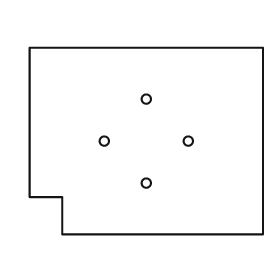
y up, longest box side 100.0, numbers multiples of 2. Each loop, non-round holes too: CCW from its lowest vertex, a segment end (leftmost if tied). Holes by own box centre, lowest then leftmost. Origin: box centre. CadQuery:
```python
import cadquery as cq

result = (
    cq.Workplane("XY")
    .moveTo(-36.0, -40.0)
    .lineTo(50.0, -40.0)
    .lineTo(50.0, 40.0)
    .lineTo(-50.0, 40.0)
    .lineTo(-50.0, -24.0)
    .lineTo(-36.0, -24.0)
    .close()
    .moveTo(0.0, -18.0)
    .circle(2.0)
    .moveTo(-18.0, 0.0)
    .circle(2.0)
    .moveTo(18.0, 0.0)
    .circle(2.0)
    .moveTo(0.0, 18.0)
    .circle(2.0)
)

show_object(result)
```